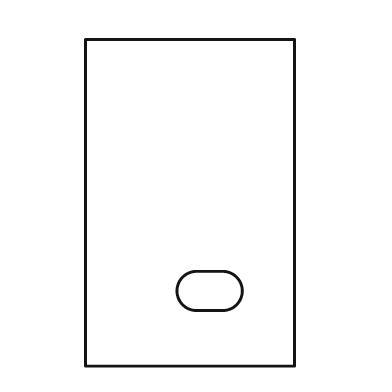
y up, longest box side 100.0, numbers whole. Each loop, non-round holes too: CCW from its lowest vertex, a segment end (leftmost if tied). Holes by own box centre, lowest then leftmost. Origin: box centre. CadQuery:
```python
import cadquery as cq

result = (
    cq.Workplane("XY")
    .moveTo(-32.0, -50.0)
    .lineTo(32.0, -50.0)
    .lineTo(32.0, 50.0)
    .lineTo(-32.0, 50.0)
    .close()
    .moveTo(2.0, -33.0)
    .lineTo(10.0, -33.0)
    .threePointArc((16.0, -27.0), (10.0, -21.0))
    .lineTo(2.0, -21.0)
    .threePointArc((-4.0, -27.0), (2.0, -33.0))
    .close()
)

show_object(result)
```